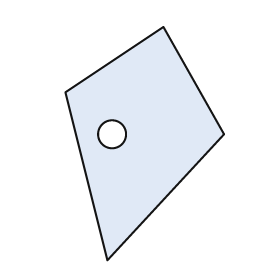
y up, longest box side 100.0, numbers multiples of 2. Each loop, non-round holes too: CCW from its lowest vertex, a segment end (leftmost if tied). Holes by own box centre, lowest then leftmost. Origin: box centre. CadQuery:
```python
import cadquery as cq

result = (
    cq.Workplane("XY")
    .moveTo(-16.0, -50.0)
    .lineTo(34.0, 4.0)
    .lineTo(8.0, 50.0)
    .lineTo(-34.0, 22.0)
    .close()
    .moveTo(-14.0, 4.0)
    .circle(6.0)
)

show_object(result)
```